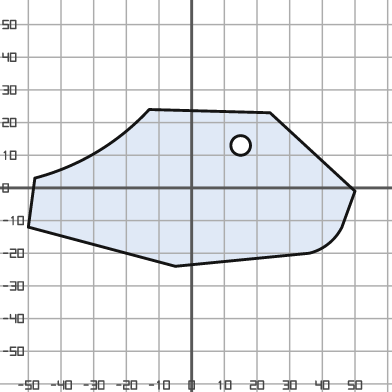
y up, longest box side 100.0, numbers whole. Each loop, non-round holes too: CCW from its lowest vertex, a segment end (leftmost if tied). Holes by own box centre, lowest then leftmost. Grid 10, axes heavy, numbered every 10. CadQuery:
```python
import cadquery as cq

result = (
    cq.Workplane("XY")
    .moveTo(-5.0, -24.0)
    .lineTo(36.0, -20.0)
    .threePointArc((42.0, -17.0), (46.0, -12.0))
    .lineTo(50.0, -1.0)
    .lineTo(24.0, 23.0)
    .lineTo(-13.0, 24.0)
    .threePointArc((-29.0, 11.0), (-48.0, 3.0))
    .lineTo(-50.0, -12.0)
    .close()
    .moveTo(15.0, 13.0)
    .circle(3.0)
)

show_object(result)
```